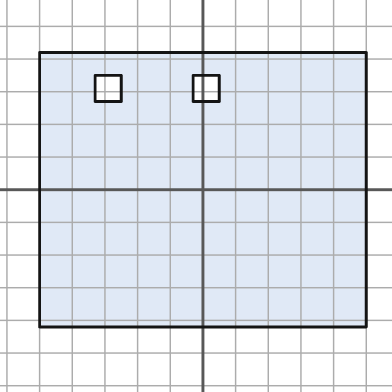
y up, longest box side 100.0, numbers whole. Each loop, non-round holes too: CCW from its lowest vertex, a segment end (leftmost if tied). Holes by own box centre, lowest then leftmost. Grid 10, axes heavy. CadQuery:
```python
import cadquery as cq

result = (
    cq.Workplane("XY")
    .moveTo(-50.0, -42.0)
    .lineTo(50.0, -42.0)
    .lineTo(50.0, 42.0)
    .lineTo(-50.0, 42.0)
    .close()
    .moveTo(-33.0, 27.0)
    .lineTo(-25.0, 27.0)
    .lineTo(-25.0, 35.0)
    .lineTo(-33.0, 35.0)
    .close()
    .moveTo(-3.0, 27.0)
    .lineTo(5.0, 27.0)
    .lineTo(5.0, 35.0)
    .lineTo(-3.0, 35.0)
    .close()
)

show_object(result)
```